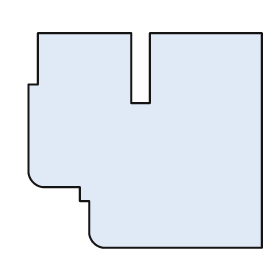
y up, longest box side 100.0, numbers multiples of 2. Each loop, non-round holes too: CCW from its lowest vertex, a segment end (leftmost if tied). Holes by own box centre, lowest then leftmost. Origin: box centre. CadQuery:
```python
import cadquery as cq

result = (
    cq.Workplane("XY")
    .moveTo(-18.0, -46.0)
    .lineTo(50.0, -46.0)
    .lineTo(50.0, 46.0)
    .lineTo(2.0, 46.0)
    .lineTo(2.0, 16.0)
    .lineTo(-6.0, 16.0)
    .lineTo(-6.0, 46.0)
    .lineTo(-46.0, 46.0)
    .lineTo(-46.0, 24.0)
    .lineTo(-50.0, 24.0)
    .lineTo(-50.0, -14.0)
    .threePointArc((-48.0, -18.0), (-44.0, -20.0))
    .lineTo(-28.0, -20.0)
    .lineTo(-28.0, -26.0)
    .lineTo(-24.0, -26.0)
    .lineTo(-24.0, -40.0)
    .threePointArc((-22.0, -44.0), (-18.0, -46.0))
    .close()
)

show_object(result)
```